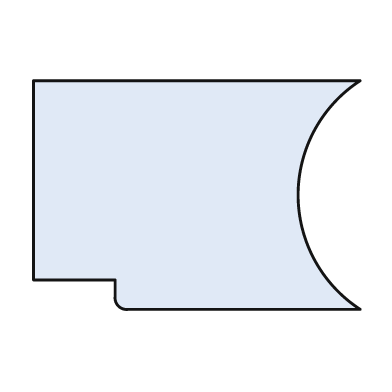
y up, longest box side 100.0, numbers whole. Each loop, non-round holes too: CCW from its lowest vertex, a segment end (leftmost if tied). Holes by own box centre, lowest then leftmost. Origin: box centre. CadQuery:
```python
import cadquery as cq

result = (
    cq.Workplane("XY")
    .moveTo(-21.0, -35.0)
    .lineTo(50.0, -35.0)
    .threePointArc((31.0, 0.0), (50.0, 35.0))
    .lineTo(-50.0, 35.0)
    .lineTo(-50.0, -26.0)
    .lineTo(-25.0, -26.0)
    .lineTo(-25.0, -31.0)
    .threePointArc((-24.0, -34.0), (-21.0, -35.0))
    .close()
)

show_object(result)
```